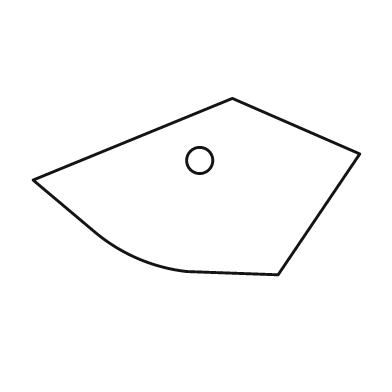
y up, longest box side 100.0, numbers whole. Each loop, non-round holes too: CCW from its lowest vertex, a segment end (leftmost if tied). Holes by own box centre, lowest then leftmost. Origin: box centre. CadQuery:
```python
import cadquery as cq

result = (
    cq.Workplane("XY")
    .moveTo(25.0, -27.0)
    .lineTo(50.0, 10.0)
    .lineTo(11.0, 27.0)
    .lineTo(-50.0, 2.0)
    .lineTo(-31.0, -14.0)
    .threePointArc((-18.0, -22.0), (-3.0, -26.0))
    .close()
    .moveTo(1.0, 8.0)
    .circle(4.0)
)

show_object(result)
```